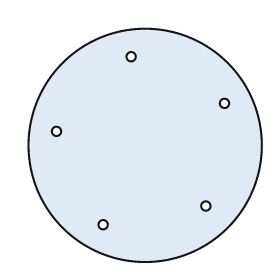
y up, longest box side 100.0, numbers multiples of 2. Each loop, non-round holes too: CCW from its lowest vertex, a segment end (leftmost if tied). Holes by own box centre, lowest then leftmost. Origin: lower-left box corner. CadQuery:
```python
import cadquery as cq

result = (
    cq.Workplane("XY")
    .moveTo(50.0, 50.0)
    .circle(50.0)
    .moveTo(32.0, 16.0)
    .circle(2.0)
    .moveTo(76.0, 24.0)
    .circle(2.0)
    .moveTo(12.0, 56.0)
    .circle(2.0)
    .moveTo(84.0, 68.0)
    .circle(2.0)
    .moveTo(44.0, 88.0)
    .circle(2.0)
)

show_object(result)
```